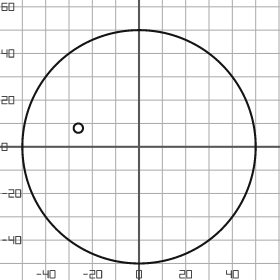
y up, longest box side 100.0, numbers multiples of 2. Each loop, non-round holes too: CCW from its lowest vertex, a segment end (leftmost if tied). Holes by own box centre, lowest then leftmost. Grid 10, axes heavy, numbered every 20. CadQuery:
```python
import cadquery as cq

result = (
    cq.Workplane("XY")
    .moveTo(0.0, 0.0)
    .circle(50.0)
    .moveTo(-26.0, 8.0)
    .circle(2.0)
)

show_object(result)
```